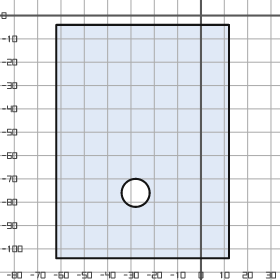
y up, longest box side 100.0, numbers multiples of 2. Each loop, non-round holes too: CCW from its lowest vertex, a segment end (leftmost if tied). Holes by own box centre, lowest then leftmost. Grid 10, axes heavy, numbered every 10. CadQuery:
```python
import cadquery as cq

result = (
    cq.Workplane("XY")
    .moveTo(-62.0, -104.0)
    .lineTo(12.0, -104.0)
    .lineTo(12.0, -4.0)
    .lineTo(-62.0, -4.0)
    .close()
    .moveTo(-28.0, -76.0)
    .circle(6.0)
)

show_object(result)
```